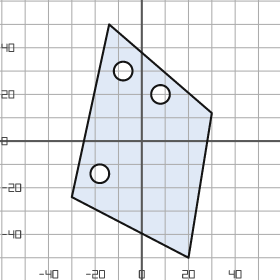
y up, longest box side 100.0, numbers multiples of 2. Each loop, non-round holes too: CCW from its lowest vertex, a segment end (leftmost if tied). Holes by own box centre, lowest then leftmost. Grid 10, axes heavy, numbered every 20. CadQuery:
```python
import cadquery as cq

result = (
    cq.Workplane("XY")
    .moveTo(20.0, -50.0)
    .lineTo(30.0, 12.0)
    .lineTo(-14.0, 50.0)
    .lineTo(-30.0, -24.0)
    .close()
    .moveTo(-18.0, -14.0)
    .circle(4.0)
    .moveTo(8.0, 20.0)
    .circle(4.0)
    .moveTo(-8.0, 30.0)
    .circle(4.0)
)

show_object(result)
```